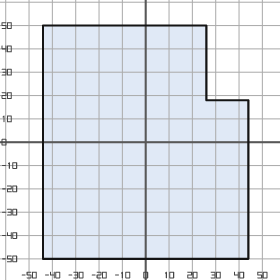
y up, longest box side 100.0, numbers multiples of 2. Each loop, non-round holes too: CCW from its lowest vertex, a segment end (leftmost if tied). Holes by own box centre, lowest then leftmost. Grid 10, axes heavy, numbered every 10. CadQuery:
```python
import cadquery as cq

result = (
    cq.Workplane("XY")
    .moveTo(-44.0, -50.0)
    .lineTo(44.0, -50.0)
    .lineTo(44.0, 18.0)
    .lineTo(26.0, 18.0)
    .lineTo(26.0, 50.0)
    .lineTo(-44.0, 50.0)
    .close()
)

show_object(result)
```